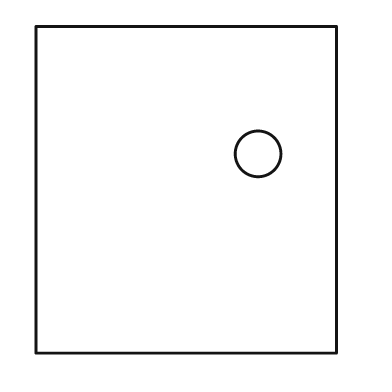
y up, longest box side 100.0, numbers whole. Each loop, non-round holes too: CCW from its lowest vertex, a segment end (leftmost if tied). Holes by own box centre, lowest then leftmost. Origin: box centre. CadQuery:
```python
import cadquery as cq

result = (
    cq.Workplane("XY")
    .moveTo(-46.0, -50.0)
    .lineTo(46.0, -50.0)
    .lineTo(46.0, 50.0)
    .lineTo(-46.0, 50.0)
    .close()
    .moveTo(22.0, 11.0)
    .circle(7.0)
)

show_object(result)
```